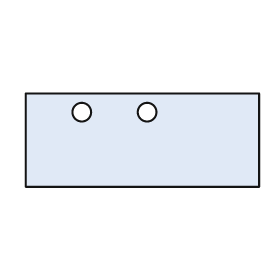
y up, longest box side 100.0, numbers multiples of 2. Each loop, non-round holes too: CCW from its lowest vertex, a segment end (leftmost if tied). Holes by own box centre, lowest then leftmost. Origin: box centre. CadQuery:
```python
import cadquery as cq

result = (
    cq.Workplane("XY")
    .moveTo(-50.0, -20.0)
    .lineTo(50.0, -20.0)
    .lineTo(50.0, 20.0)
    .lineTo(-50.0, 20.0)
    .close()
    .moveTo(-26.0, 12.0)
    .circle(4.0)
    .moveTo(2.0, 12.0)
    .circle(4.0)
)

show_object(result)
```